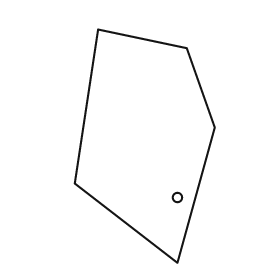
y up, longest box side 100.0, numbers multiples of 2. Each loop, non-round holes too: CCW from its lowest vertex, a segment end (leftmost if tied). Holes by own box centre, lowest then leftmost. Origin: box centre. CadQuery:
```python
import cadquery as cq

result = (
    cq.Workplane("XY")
    .moveTo(14.0, -50.0)
    .lineTo(30.0, 8.0)
    .lineTo(18.0, 42.0)
    .lineTo(-20.0, 50.0)
    .lineTo(-30.0, -16.0)
    .close()
    .moveTo(14.0, -22.0)
    .circle(2.0)
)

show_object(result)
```